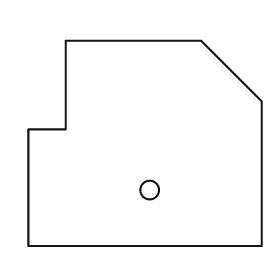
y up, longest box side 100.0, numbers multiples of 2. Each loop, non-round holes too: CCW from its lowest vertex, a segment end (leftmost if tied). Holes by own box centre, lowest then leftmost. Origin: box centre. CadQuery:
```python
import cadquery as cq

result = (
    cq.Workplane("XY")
    .moveTo(-50.0, -44.0)
    .lineTo(50.0, -44.0)
    .lineTo(50.0, 18.0)
    .lineTo(24.0, 44.0)
    .lineTo(-34.0, 44.0)
    .lineTo(-34.0, 6.0)
    .lineTo(-50.0, 6.0)
    .close()
    .moveTo(2.0, -20.0)
    .circle(4.0)
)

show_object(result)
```